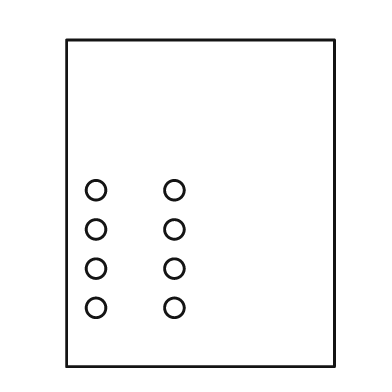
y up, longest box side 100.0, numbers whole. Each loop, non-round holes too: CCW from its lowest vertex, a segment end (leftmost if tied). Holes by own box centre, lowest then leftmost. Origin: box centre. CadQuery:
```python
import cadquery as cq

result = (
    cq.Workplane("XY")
    .moveTo(-41.0, -50.0)
    .lineTo(41.0, -50.0)
    .lineTo(41.0, 50.0)
    .lineTo(-41.0, 50.0)
    .close()
    .moveTo(-32.0, -32.0)
    .circle(3.0)
    .moveTo(-8.0, -32.0)
    .circle(3.0)
    .moveTo(-32.0, -20.0)
    .circle(3.0)
    .moveTo(-8.0, -20.0)
    .circle(3.0)
    .moveTo(-32.0, -8.0)
    .circle(3.0)
    .moveTo(-8.0, -8.0)
    .circle(3.0)
    .moveTo(-32.0, 4.0)
    .circle(3.0)
    .moveTo(-8.0, 4.0)
    .circle(3.0)
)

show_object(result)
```